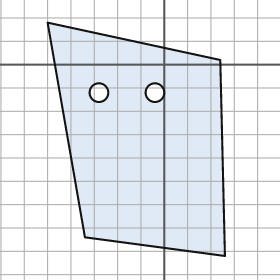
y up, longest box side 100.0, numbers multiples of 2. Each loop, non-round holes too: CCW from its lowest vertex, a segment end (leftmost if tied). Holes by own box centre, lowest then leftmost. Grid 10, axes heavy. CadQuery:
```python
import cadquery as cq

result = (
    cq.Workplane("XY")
    .moveTo(26.0, -82.0)
    .lineTo(24.0, 2.0)
    .lineTo(-50.0, 18.0)
    .lineTo(-34.0, -74.0)
    .close()
    .moveTo(-28.0, -12.0)
    .circle(4.0)
    .moveTo(-4.0, -12.0)
    .circle(4.0)
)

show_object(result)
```